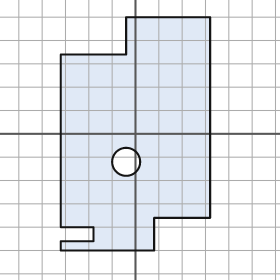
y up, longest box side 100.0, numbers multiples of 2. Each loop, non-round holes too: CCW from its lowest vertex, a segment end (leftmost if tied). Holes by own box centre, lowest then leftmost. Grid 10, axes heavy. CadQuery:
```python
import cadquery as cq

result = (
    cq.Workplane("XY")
    .moveTo(-32.0, -50.0)
    .lineTo(8.0, -50.0)
    .lineTo(8.0, -36.0)
    .lineTo(32.0, -36.0)
    .lineTo(32.0, 50.0)
    .lineTo(-4.0, 50.0)
    .lineTo(-4.0, 34.0)
    .lineTo(-32.0, 34.0)
    .lineTo(-32.0, -40.0)
    .lineTo(-18.0, -40.0)
    .lineTo(-18.0, -46.0)
    .lineTo(-32.0, -46.0)
    .close()
    .moveTo(-4.0, -12.0)
    .circle(6.0)
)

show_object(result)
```